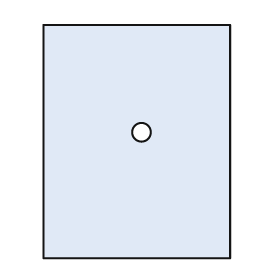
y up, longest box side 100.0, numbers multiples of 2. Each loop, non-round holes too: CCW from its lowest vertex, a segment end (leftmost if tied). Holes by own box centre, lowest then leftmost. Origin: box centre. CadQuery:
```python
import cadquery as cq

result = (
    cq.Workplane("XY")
    .moveTo(-40.0, -50.0)
    .lineTo(40.0, -50.0)
    .lineTo(40.0, 50.0)
    .lineTo(-40.0, 50.0)
    .close()
    .moveTo(2.0, 4.0)
    .circle(4.0)
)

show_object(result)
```